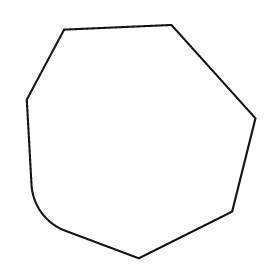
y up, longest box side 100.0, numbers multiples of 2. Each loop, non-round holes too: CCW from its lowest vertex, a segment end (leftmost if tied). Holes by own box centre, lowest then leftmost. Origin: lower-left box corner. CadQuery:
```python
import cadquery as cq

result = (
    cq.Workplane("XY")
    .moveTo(48.0, 0.0)
    .lineTo(88.0, 20.0)
    .lineTo(98.0, 60.0)
    .lineTo(62.0, 100.0)
    .lineTo(16.0, 98.0)
    .lineTo(0.0, 68.0)
    .lineTo(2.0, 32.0)
    .threePointArc((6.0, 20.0), (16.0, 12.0))
    .close()
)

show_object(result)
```